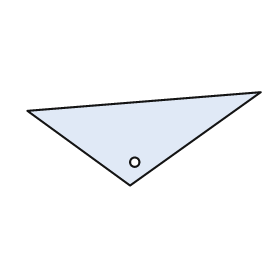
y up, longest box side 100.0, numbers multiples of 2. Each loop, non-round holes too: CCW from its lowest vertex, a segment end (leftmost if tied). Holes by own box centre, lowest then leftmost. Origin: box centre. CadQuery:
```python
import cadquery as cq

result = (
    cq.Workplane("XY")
    .moveTo(-6.0, -20.0)
    .lineTo(50.0, 20.0)
    .lineTo(-50.0, 12.0)
    .close()
    .moveTo(-4.0, -10.0)
    .circle(2.0)
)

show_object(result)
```